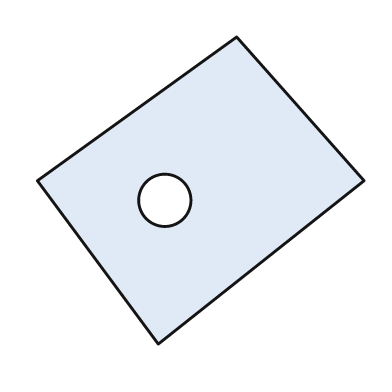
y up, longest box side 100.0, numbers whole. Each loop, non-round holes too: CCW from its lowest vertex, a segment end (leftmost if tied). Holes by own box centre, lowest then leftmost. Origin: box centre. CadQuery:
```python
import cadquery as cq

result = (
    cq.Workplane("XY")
    .moveTo(-13.0, -47.0)
    .lineTo(50.0, 3.0)
    .lineTo(11.0, 47.0)
    .lineTo(-50.0, 3.0)
    .close()
    .moveTo(-11.0, -3.0)
    .circle(8.0)
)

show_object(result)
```